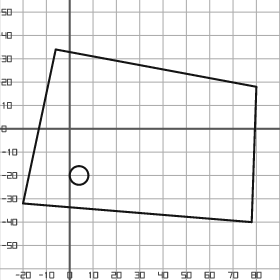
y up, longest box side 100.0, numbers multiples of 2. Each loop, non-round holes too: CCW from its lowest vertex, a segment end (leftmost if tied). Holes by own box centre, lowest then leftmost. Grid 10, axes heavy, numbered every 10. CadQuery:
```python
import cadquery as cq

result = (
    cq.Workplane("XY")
    .moveTo(78.0, -40.0)
    .lineTo(80.0, 18.0)
    .lineTo(-6.0, 34.0)
    .lineTo(-20.0, -32.0)
    .close()
    .moveTo(4.0, -20.0)
    .circle(4.0)
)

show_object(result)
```